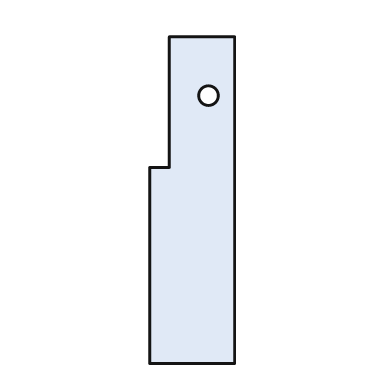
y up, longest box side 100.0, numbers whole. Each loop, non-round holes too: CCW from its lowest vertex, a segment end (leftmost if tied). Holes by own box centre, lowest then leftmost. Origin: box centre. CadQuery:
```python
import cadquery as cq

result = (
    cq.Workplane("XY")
    .moveTo(-13.0, -50.0)
    .lineTo(13.0, -50.0)
    .lineTo(13.0, 50.0)
    .lineTo(-7.0, 50.0)
    .lineTo(-7.0, 10.0)
    .lineTo(-13.0, 10.0)
    .close()
    .moveTo(5.0, 32.0)
    .circle(3.0)
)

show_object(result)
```